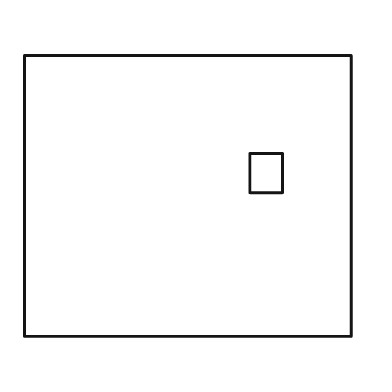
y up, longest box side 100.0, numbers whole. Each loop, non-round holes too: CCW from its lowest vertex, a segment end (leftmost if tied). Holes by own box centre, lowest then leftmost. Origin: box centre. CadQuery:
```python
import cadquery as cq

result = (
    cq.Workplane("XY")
    .moveTo(-50.0, -43.0)
    .lineTo(50.0, -43.0)
    .lineTo(50.0, 43.0)
    .lineTo(-50.0, 43.0)
    .close()
    .moveTo(19.0, 1.0)
    .lineTo(29.0, 1.0)
    .lineTo(29.0, 13.0)
    .lineTo(19.0, 13.0)
    .close()
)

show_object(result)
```